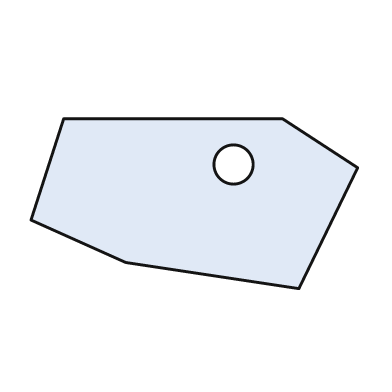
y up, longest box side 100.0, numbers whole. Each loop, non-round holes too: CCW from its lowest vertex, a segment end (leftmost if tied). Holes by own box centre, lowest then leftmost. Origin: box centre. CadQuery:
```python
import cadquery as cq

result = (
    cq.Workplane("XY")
    .moveTo(32.0, -26.0)
    .lineTo(50.0, 11.0)
    .lineTo(27.0, 26.0)
    .lineTo(-40.0, 26.0)
    .lineTo(-50.0, -5.0)
    .lineTo(-21.0, -18.0)
    .close()
    .moveTo(12.0, 12.0)
    .circle(6.0)
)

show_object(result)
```